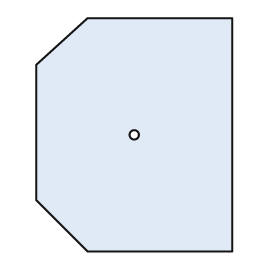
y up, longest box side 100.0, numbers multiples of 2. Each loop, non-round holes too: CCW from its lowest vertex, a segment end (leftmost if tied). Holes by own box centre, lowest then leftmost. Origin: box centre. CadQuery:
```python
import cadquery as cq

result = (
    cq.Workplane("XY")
    .moveTo(-20.0, -50.0)
    .lineTo(42.0, -50.0)
    .lineTo(42.0, 50.0)
    .lineTo(-20.0, 50.0)
    .lineTo(-42.0, 30.0)
    .lineTo(-42.0, -28.0)
    .close()
    .moveTo(0.0, 0.0)
    .circle(2.0)
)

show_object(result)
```